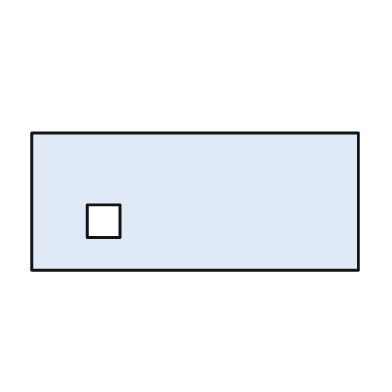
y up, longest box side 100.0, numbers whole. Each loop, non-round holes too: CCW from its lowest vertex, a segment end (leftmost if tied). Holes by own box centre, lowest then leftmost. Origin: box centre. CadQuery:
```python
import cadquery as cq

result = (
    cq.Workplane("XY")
    .moveTo(-50.0, -21.0)
    .lineTo(50.0, -21.0)
    .lineTo(50.0, 21.0)
    .lineTo(-50.0, 21.0)
    .close()
    .moveTo(-33.0, -11.0)
    .lineTo(-23.0, -11.0)
    .lineTo(-23.0, -1.0)
    .lineTo(-33.0, -1.0)
    .close()
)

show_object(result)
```